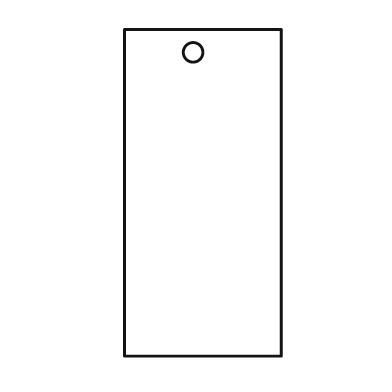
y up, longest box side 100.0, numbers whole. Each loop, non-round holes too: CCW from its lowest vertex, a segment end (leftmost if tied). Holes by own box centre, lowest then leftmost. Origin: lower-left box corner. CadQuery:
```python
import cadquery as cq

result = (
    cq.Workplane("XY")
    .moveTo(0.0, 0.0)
    .lineTo(48.0, 0.0)
    .lineTo(48.0, 100.0)
    .lineTo(0.0, 100.0)
    .close()
    .moveTo(21.0, 93.0)
    .circle(3.0)
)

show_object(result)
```